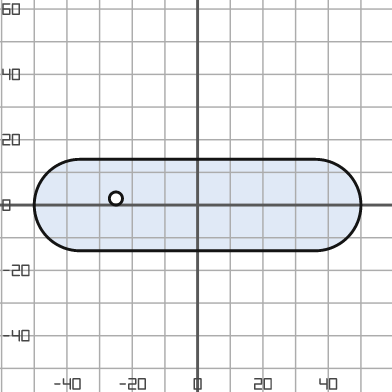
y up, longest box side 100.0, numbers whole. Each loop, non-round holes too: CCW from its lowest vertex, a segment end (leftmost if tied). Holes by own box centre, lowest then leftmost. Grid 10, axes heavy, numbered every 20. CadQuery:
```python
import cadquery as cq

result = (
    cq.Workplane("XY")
    .moveTo(-36.0, -14.0)
    .lineTo(36.0, -14.0)
    .threePointArc((50.0, 0.0), (36.0, 14.0))
    .lineTo(-36.0, 14.0)
    .threePointArc((-50.0, 0.0), (-36.0, -14.0))
    .close()
    .moveTo(-25.0, 2.0)
    .circle(2.0)
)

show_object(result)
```